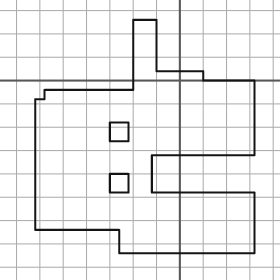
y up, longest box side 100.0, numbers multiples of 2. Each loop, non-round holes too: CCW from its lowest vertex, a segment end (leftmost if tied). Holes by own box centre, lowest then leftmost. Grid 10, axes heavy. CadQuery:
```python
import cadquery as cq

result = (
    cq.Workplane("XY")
    .moveTo(-26.0, -74.0)
    .lineTo(32.0, -74.0)
    .lineTo(32.0, -48.0)
    .lineTo(-12.0, -48.0)
    .lineTo(-12.0, -32.0)
    .lineTo(32.0, -32.0)
    .lineTo(32.0, 0.0)
    .lineTo(10.0, 0.0)
    .lineTo(10.0, 4.0)
    .lineTo(-10.0, 4.0)
    .lineTo(-10.0, 26.0)
    .lineTo(-20.0, 26.0)
    .lineTo(-20.0, -4.0)
    .lineTo(-58.0, -4.0)
    .lineTo(-58.0, -8.0)
    .lineTo(-62.0, -8.0)
    .lineTo(-62.0, -64.0)
    .lineTo(-26.0, -64.0)
    .close()
    .moveTo(-30.0, -48.0)
    .lineTo(-22.0, -48.0)
    .lineTo(-22.0, -40.0)
    .lineTo(-30.0, -40.0)
    .close()
    .moveTo(-30.0, -26.0)
    .lineTo(-22.0, -26.0)
    .lineTo(-22.0, -18.0)
    .lineTo(-30.0, -18.0)
    .close()
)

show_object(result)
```